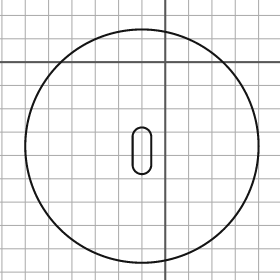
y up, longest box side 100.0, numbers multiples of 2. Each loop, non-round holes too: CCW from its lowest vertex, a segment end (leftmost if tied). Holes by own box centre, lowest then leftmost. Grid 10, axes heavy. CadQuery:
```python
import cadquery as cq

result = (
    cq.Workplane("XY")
    .moveTo(-10.0, -36.0)
    .circle(50.0)
    .moveTo(-14.0, -44.0)
    .threePointArc((-10.0, -48.0), (-6.0, -44.0))
    .lineTo(-6.0, -32.0)
    .threePointArc((-10.0, -28.0), (-14.0, -32.0))
    .close()
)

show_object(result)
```